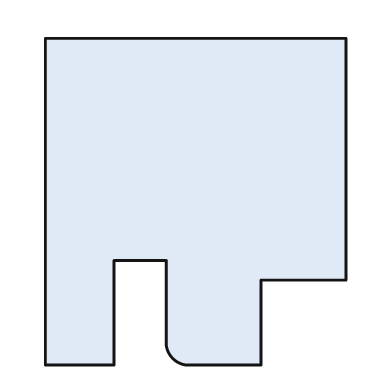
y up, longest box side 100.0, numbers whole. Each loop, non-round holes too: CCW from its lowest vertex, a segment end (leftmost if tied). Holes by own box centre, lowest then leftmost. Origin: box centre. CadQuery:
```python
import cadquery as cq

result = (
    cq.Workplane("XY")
    .moveTo(-46.0, -50.0)
    .lineTo(-25.0, -50.0)
    .lineTo(-25.0, -18.0)
    .lineTo(-9.0, -18.0)
    .lineTo(-9.0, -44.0)
    .threePointArc((-7.0, -48.0), (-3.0, -50.0))
    .lineTo(20.0, -50.0)
    .lineTo(20.0, -24.0)
    .lineTo(46.0, -24.0)
    .lineTo(46.0, 50.0)
    .lineTo(-46.0, 50.0)
    .close()
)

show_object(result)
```